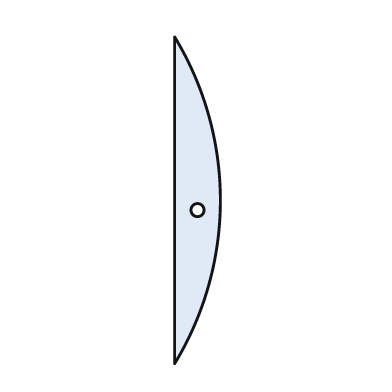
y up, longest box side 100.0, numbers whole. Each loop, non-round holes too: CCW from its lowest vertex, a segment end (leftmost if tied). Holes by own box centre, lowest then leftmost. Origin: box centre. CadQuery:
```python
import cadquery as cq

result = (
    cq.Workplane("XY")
    .moveTo(-7.0, -50.0)
    .threePointArc((7.0, 0.0), (-7.0, 50.0))
    .close()
    .moveTo(0.0, -3.0)
    .circle(2.0)
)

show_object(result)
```